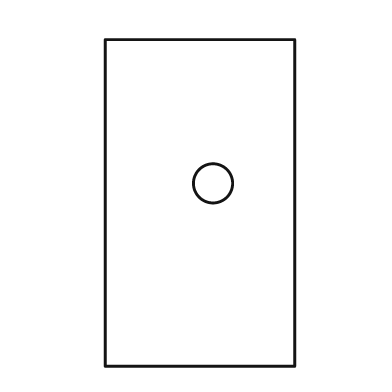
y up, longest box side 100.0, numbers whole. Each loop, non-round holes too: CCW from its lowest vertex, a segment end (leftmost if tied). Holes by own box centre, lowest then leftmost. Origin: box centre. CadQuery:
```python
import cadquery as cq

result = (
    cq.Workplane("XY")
    .moveTo(-29.0, -50.0)
    .lineTo(29.0, -50.0)
    .lineTo(29.0, 50.0)
    .lineTo(-29.0, 50.0)
    .close()
    .moveTo(4.0, 6.0)
    .circle(6.0)
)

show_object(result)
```